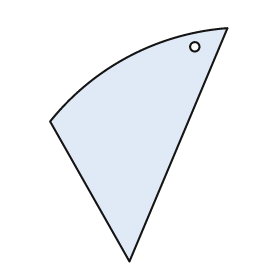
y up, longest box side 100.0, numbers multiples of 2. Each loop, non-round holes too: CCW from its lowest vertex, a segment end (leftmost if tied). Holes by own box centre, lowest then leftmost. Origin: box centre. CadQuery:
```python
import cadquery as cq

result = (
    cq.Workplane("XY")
    .moveTo(-4.0, -50.0)
    .lineTo(38.0, 50.0)
    .threePointArc((-4.0, 38.0), (-38.0, 10.0))
    .close()
    .moveTo(24.0, 42.0)
    .circle(2.0)
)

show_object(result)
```